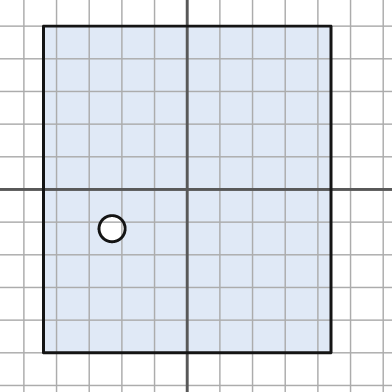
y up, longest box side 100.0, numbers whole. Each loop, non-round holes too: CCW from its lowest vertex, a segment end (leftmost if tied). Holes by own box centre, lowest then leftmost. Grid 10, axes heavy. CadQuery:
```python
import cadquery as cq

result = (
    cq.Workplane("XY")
    .moveTo(-44.0, -50.0)
    .lineTo(44.0, -50.0)
    .lineTo(44.0, 50.0)
    .lineTo(-44.0, 50.0)
    .close()
    .moveTo(-23.0, -12.0)
    .circle(4.0)
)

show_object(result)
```